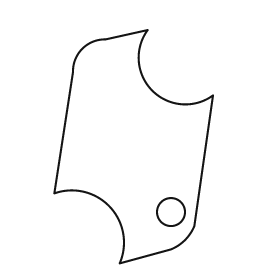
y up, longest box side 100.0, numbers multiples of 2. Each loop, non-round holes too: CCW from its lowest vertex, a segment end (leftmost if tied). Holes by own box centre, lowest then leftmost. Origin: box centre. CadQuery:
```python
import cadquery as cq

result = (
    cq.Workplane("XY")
    .moveTo(-6.0, -50.0)
    .lineTo(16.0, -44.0)
    .threePointArc((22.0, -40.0), (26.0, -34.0))
    .lineTo(34.0, 22.0)
    .threePointArc((8.0, 24.0), (6.0, 50.0))
    .lineTo(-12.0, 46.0)
    .threePointArc((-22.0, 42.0), (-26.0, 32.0))
    .lineTo(-34.0, -20.0)
    .threePointArc((-10.0, -26.0), (-6.0, -50.0))
    .close()
    .moveTo(16.0, -28.0)
    .circle(6.0)
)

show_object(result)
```